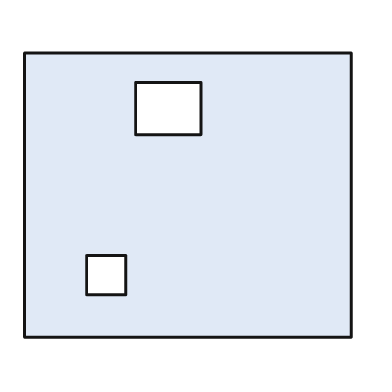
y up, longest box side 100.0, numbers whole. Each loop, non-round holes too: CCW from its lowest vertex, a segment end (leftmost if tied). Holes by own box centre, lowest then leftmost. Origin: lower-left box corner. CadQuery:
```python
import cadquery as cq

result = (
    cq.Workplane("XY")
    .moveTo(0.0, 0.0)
    .lineTo(100.0, 0.0)
    .lineTo(100.0, 87.0)
    .lineTo(0.0, 87.0)
    .close()
    .moveTo(19.0, 13.0)
    .lineTo(31.0, 13.0)
    .lineTo(31.0, 25.0)
    .lineTo(19.0, 25.0)
    .close()
    .moveTo(34.0, 62.0)
    .lineTo(54.0, 62.0)
    .lineTo(54.0, 78.0)
    .lineTo(34.0, 78.0)
    .close()
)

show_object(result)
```